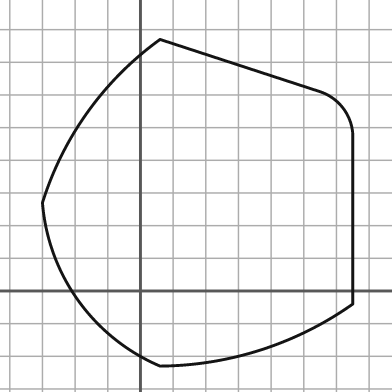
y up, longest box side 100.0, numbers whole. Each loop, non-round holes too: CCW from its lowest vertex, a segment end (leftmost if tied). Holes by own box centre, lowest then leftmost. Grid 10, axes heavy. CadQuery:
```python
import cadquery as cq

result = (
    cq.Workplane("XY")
    .moveTo(6.0, -23.0)
    .threePointArc((37.0, -18.0), (65.0, -4.0))
    .lineTo(65.0, 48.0)
    .threePointArc((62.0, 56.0), (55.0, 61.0))
    .lineTo(6.0, 77.0)
    .threePointArc((-16.0, 55.0), (-30.0, 27.0))
    .threePointArc((-19.0, -3.0), (6.0, -23.0))
    .close()
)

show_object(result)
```